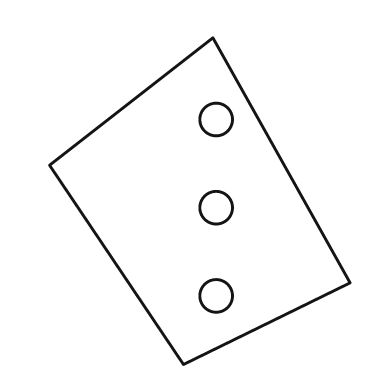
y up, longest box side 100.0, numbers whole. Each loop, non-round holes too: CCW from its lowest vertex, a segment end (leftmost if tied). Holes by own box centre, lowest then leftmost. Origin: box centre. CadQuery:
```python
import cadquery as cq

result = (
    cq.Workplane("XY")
    .moveTo(-5.0, -50.0)
    .lineTo(46.0, -25.0)
    .lineTo(4.0, 50.0)
    .lineTo(-46.0, 11.0)
    .close()
    .moveTo(5.0, -29.0)
    .circle(5.0)
    .moveTo(5.0, -2.0)
    .circle(5.0)
    .moveTo(5.0, 25.0)
    .circle(5.0)
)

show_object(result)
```